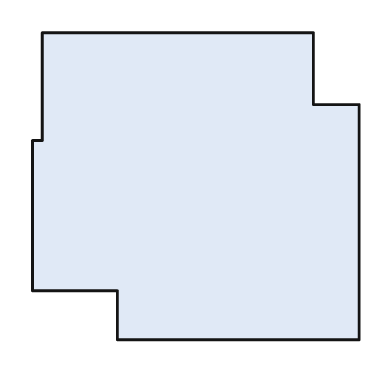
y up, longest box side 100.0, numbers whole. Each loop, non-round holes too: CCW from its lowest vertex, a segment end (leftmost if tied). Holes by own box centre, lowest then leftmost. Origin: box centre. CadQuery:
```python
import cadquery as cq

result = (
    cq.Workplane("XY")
    .moveTo(-24.0, -47.0)
    .lineTo(50.0, -47.0)
    .lineTo(50.0, 25.0)
    .lineTo(36.0, 25.0)
    .lineTo(36.0, 47.0)
    .lineTo(-47.0, 47.0)
    .lineTo(-47.0, 14.0)
    .lineTo(-50.0, 14.0)
    .lineTo(-50.0, -32.0)
    .lineTo(-24.0, -32.0)
    .close()
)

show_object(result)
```